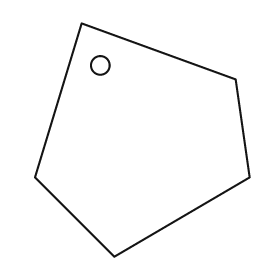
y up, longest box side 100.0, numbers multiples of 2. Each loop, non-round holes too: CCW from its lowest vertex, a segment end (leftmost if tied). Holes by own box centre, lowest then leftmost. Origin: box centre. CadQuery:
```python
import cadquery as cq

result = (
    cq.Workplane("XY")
    .moveTo(-12.0, -50.0)
    .lineTo(46.0, -16.0)
    .lineTo(40.0, 26.0)
    .lineTo(-26.0, 50.0)
    .lineTo(-46.0, -16.0)
    .close()
    .moveTo(-18.0, 32.0)
    .circle(4.0)
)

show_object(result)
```